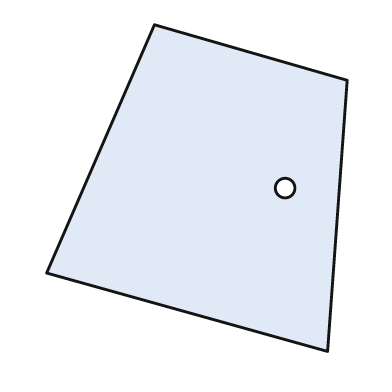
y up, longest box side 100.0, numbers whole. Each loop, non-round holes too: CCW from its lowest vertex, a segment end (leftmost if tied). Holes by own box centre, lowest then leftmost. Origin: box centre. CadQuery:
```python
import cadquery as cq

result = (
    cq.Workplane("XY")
    .moveTo(40.0, -50.0)
    .lineTo(46.0, 33.0)
    .lineTo(-13.0, 50.0)
    .lineTo(-46.0, -26.0)
    .close()
    .moveTo(27.0, 0.0)
    .circle(3.0)
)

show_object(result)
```